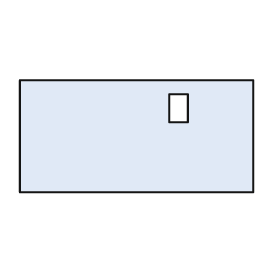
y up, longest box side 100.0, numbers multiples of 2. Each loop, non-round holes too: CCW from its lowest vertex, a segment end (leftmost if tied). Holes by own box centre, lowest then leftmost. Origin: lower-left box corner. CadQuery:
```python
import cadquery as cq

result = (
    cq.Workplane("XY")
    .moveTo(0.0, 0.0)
    .lineTo(100.0, 0.0)
    .lineTo(100.0, 48.0)
    .lineTo(0.0, 48.0)
    .close()
    .moveTo(64.0, 30.0)
    .lineTo(72.0, 30.0)
    .lineTo(72.0, 42.0)
    .lineTo(64.0, 42.0)
    .close()
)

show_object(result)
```